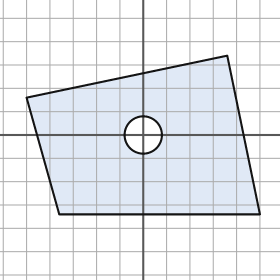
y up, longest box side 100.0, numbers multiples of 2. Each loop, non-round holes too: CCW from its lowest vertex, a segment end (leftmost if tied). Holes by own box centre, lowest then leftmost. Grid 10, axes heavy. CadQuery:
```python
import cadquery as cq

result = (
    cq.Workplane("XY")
    .moveTo(-36.0, -34.0)
    .lineTo(50.0, -34.0)
    .lineTo(36.0, 34.0)
    .lineTo(-50.0, 16.0)
    .close()
    .moveTo(0.0, 0.0)
    .circle(8.0)
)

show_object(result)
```